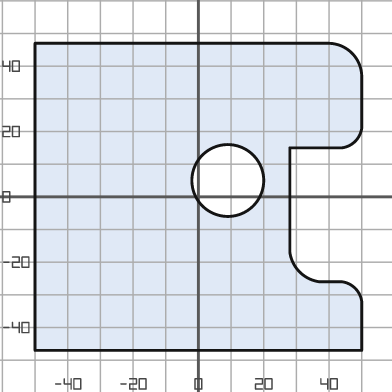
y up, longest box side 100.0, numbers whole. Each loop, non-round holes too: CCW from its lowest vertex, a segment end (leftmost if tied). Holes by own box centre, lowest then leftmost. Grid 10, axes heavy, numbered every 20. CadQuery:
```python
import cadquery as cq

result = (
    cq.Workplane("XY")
    .moveTo(-50.0, -47.0)
    .lineTo(50.0, -47.0)
    .lineTo(50.0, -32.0)
    .threePointArc((48.0, -28.0), (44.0, -26.0))
    .lineTo(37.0, -26.0)
    .threePointArc((31.0, -23.0), (28.0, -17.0))
    .lineTo(28.0, 15.0)
    .lineTo(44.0, 15.0)
    .threePointArc((48.0, 17.0), (50.0, 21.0))
    .lineTo(50.0, 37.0)
    .threePointArc((47.0, 44.0), (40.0, 47.0))
    .lineTo(-50.0, 47.0)
    .close()
    .moveTo(9.0, 5.0)
    .circle(11.0)
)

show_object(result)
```